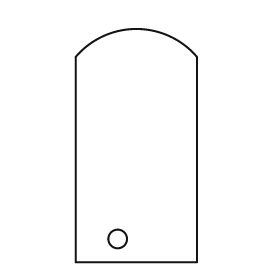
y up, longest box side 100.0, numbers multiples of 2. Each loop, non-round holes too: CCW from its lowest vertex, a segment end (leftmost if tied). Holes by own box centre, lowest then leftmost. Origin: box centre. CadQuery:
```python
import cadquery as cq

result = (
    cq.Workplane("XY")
    .moveTo(-26.0, -50.0)
    .lineTo(26.0, -50.0)
    .lineTo(26.0, 38.0)
    .threePointArc((0.0, 50.0), (-26.0, 38.0))
    .close()
    .moveTo(-8.0, -40.0)
    .circle(4.0)
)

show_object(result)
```